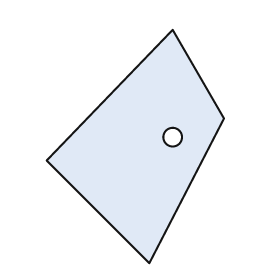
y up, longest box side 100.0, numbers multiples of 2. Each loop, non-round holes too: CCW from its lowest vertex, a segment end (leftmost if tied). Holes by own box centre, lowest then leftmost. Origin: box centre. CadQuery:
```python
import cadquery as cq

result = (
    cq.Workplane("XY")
    .moveTo(6.0, -50.0)
    .lineTo(38.0, 12.0)
    .lineTo(16.0, 50.0)
    .lineTo(-38.0, -6.0)
    .close()
    .moveTo(16.0, 4.0)
    .circle(4.0)
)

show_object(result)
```